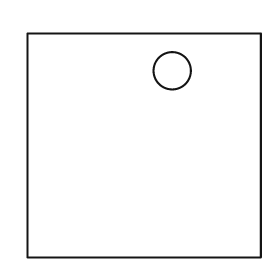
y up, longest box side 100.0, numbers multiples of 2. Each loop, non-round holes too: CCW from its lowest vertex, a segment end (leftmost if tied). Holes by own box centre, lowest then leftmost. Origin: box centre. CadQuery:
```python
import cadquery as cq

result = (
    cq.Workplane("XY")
    .moveTo(-50.0, -48.0)
    .lineTo(50.0, -48.0)
    .lineTo(50.0, 48.0)
    .lineTo(-50.0, 48.0)
    .close()
    .moveTo(12.0, 32.0)
    .circle(8.0)
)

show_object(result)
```